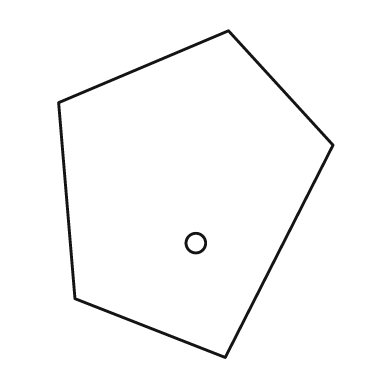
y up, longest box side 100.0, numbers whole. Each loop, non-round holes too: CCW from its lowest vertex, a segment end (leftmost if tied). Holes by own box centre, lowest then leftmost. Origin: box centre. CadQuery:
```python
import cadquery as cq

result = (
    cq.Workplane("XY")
    .moveTo(9.0, -50.0)
    .lineTo(42.0, 15.0)
    .lineTo(10.0, 50.0)
    .lineTo(-42.0, 28.0)
    .lineTo(-37.0, -32.0)
    .close()
    .moveTo(0.0, -15.0)
    .circle(3.0)
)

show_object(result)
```